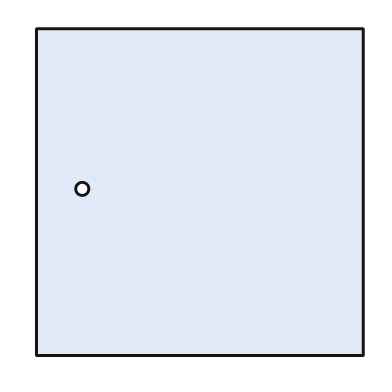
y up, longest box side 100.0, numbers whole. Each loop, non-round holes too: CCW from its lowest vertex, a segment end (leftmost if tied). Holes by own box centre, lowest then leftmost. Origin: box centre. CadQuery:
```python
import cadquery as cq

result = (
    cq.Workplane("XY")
    .moveTo(-50.0, -50.0)
    .lineTo(50.0, -50.0)
    .lineTo(50.0, 50.0)
    .lineTo(-50.0, 50.0)
    .close()
    .moveTo(-36.0, 1.0)
    .circle(2.0)
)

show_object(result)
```